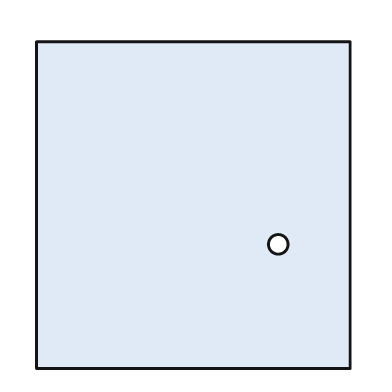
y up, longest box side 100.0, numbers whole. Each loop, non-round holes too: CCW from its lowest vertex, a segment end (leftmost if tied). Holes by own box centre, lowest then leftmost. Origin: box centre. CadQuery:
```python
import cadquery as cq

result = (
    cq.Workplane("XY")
    .moveTo(-48.0, -50.0)
    .lineTo(48.0, -50.0)
    .lineTo(48.0, 50.0)
    .lineTo(-48.0, 50.0)
    .close()
    .moveTo(26.0, -12.0)
    .circle(3.0)
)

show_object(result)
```